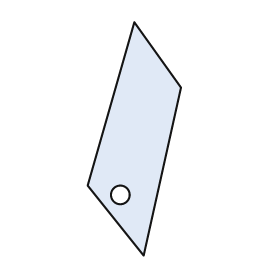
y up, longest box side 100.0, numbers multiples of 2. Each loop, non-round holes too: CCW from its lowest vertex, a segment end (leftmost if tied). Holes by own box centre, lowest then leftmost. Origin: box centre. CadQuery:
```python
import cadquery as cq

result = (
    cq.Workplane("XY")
    .moveTo(4.0, -50.0)
    .lineTo(20.0, 22.0)
    .lineTo(0.0, 50.0)
    .lineTo(-20.0, -20.0)
    .close()
    .moveTo(-6.0, -24.0)
    .circle(4.0)
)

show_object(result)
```